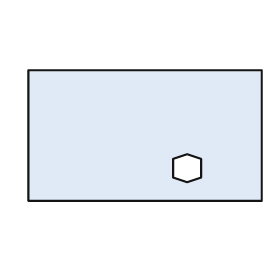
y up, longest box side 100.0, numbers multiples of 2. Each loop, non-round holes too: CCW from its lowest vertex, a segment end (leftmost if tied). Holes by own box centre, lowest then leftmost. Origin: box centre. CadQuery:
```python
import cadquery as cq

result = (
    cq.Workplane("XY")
    .moveTo(-50.0, -28.0)
    .lineTo(50.0, -28.0)
    .lineTo(50.0, 28.0)
    .lineTo(-50.0, 28.0)
    .close()
    .moveTo(18.0, -20.0)
    .lineTo(24.0, -18.0)
    .lineTo(24.0, -10.0)
    .lineTo(18.0, -8.0)
    .lineTo(12.0, -10.0)
    .lineTo(12.0, -18.0)
    .close()
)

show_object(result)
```